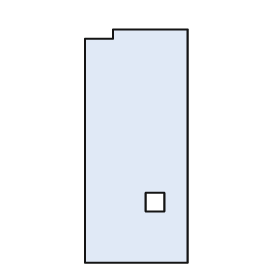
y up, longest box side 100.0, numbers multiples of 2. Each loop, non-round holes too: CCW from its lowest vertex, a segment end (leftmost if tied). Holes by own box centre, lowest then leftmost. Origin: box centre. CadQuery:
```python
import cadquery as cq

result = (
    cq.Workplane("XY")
    .moveTo(-22.0, -50.0)
    .lineTo(22.0, -50.0)
    .lineTo(22.0, 50.0)
    .lineTo(-10.0, 50.0)
    .lineTo(-10.0, 46.0)
    .lineTo(-22.0, 46.0)
    .close()
    .moveTo(4.0, -28.0)
    .lineTo(12.0, -28.0)
    .lineTo(12.0, -20.0)
    .lineTo(4.0, -20.0)
    .close()
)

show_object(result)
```